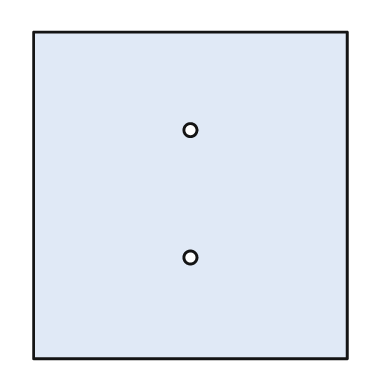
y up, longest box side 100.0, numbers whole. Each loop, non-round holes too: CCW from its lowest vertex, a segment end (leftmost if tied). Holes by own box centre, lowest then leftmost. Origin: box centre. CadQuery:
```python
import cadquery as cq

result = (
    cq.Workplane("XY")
    .moveTo(-48.0, -50.0)
    .lineTo(48.0, -50.0)
    .lineTo(48.0, 50.0)
    .lineTo(-48.0, 50.0)
    .close()
    .moveTo(0.0, -19.0)
    .circle(2.0)
    .moveTo(0.0, 20.0)
    .circle(2.0)
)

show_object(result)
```